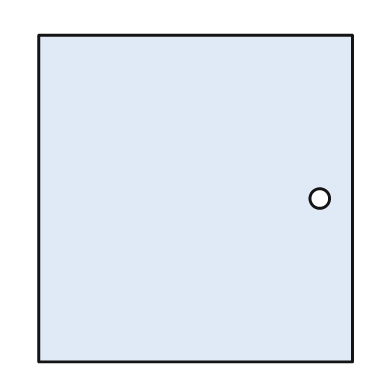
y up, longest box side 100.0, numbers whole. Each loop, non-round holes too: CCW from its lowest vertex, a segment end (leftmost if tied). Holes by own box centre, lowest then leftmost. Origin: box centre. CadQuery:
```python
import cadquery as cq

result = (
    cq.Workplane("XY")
    .moveTo(-48.0, -50.0)
    .lineTo(48.0, -50.0)
    .lineTo(48.0, 50.0)
    .lineTo(-48.0, 50.0)
    .close()
    .moveTo(38.0, 0.0)
    .circle(3.0)
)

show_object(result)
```